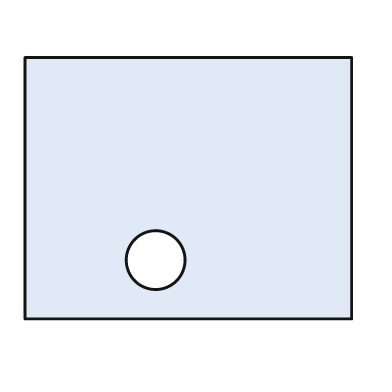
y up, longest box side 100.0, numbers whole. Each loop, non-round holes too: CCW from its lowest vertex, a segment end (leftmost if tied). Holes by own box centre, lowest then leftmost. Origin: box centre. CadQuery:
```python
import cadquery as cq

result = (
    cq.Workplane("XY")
    .moveTo(-50.0, -40.0)
    .lineTo(50.0, -40.0)
    .lineTo(50.0, 40.0)
    .lineTo(-50.0, 40.0)
    .close()
    .moveTo(-10.0, -22.0)
    .circle(9.0)
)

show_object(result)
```